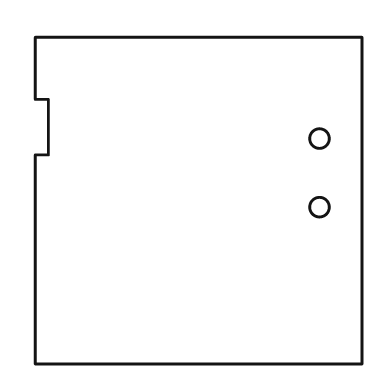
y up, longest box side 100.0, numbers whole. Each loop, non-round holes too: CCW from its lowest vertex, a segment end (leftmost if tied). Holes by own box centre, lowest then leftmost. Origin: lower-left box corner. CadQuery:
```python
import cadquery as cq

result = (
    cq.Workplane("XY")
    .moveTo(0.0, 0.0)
    .lineTo(100.0, 0.0)
    .lineTo(100.0, 100.0)
    .lineTo(0.0, 100.0)
    .lineTo(0.0, 81.0)
    .lineTo(4.0, 81.0)
    .lineTo(4.0, 64.0)
    .lineTo(0.0, 64.0)
    .close()
    .moveTo(87.0, 48.0)
    .circle(3.0)
    .moveTo(87.0, 69.0)
    .circle(3.0)
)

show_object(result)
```